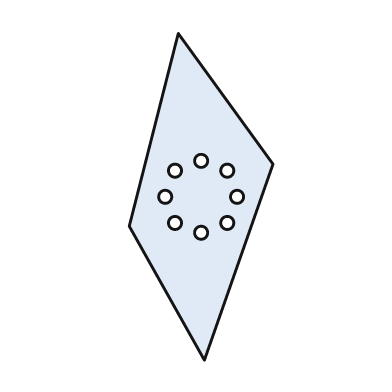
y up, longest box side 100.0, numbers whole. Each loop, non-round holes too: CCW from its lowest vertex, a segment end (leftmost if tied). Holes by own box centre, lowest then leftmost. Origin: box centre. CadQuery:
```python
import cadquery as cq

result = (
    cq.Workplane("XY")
    .moveTo(1.0, -50.0)
    .lineTo(22.0, 10.0)
    .lineTo(-7.0, 50.0)
    .lineTo(-22.0, -9.0)
    .close()
    .moveTo(0.0, -11.0)
    .circle(2.0)
    .moveTo(-8.0, -8.0)
    .circle(2.0)
    .moveTo(8.0, -8.0)
    .circle(2.0)
    .moveTo(-11.0, 0.0)
    .circle(2.0)
    .moveTo(11.0, 0.0)
    .circle(2.0)
    .moveTo(-8.0, 8.0)
    .circle(2.0)
    .moveTo(8.0, 8.0)
    .circle(2.0)
    .moveTo(0.0, 11.0)
    .circle(2.0)
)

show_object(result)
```